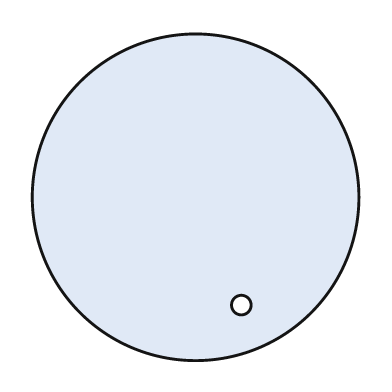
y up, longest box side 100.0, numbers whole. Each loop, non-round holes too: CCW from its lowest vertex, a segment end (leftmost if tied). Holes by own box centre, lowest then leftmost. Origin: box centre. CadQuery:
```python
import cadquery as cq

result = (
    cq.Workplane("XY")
    .moveTo(0.0, 0.0)
    .circle(50.0)
    .moveTo(14.0, -33.0)
    .circle(3.0)
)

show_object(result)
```